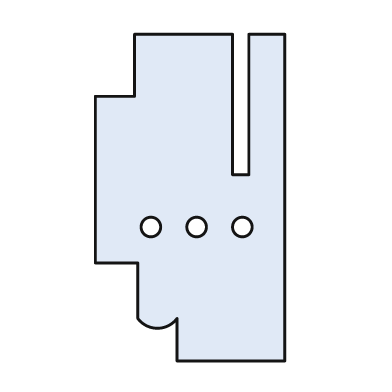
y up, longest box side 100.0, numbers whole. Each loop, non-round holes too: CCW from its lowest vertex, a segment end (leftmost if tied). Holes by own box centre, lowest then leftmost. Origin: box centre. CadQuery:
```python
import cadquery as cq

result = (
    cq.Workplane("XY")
    .moveTo(-4.0, -50.0)
    .lineTo(29.0, -50.0)
    .lineTo(29.0, 50.0)
    .lineTo(18.0, 50.0)
    .lineTo(18.0, 7.0)
    .lineTo(13.0, 7.0)
    .lineTo(13.0, 50.0)
    .lineTo(-17.0, 50.0)
    .lineTo(-17.0, 31.0)
    .lineTo(-29.0, 31.0)
    .lineTo(-29.0, -20.0)
    .lineTo(-16.0, -20.0)
    .lineTo(-16.0, -37.0)
    .threePointArc((-10.0, -40.0), (-4.0, -37.0))
    .close()
    .moveTo(-12.0, -9.0)
    .circle(3.0)
    .moveTo(2.0, -9.0)
    .circle(3.0)
    .moveTo(16.0, -9.0)
    .circle(3.0)
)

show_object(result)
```